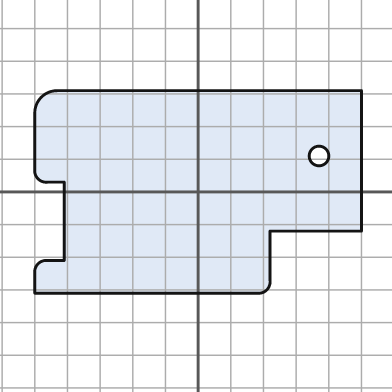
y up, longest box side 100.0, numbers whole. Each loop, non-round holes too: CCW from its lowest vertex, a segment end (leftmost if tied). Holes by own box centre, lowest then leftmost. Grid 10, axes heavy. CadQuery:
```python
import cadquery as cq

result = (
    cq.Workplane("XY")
    .moveTo(-50.0, -31.0)
    .lineTo(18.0, -31.0)
    .threePointArc((21.0, -30.0), (22.0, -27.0))
    .lineTo(22.0, -12.0)
    .lineTo(50.0, -12.0)
    .lineTo(50.0, 31.0)
    .lineTo(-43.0, 31.0)
    .threePointArc((-48.0, 29.0), (-50.0, 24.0))
    .lineTo(-50.0, 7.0)
    .threePointArc((-49.0, 4.0), (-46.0, 3.0))
    .lineTo(-41.0, 3.0)
    .lineTo(-41.0, -21.0)
    .lineTo(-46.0, -21.0)
    .threePointArc((-49.0, -22.0), (-50.0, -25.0))
    .close()
    .moveTo(37.0, 11.0)
    .circle(3.0)
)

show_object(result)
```